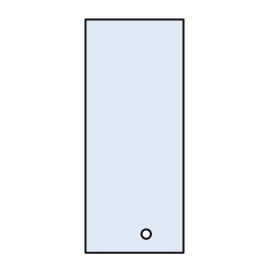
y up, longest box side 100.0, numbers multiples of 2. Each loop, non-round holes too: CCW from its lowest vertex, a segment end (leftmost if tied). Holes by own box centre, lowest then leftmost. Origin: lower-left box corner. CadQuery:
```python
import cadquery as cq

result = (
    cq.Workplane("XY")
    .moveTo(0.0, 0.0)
    .lineTo(42.0, 0.0)
    .lineTo(42.0, 100.0)
    .lineTo(0.0, 100.0)
    .close()
    .moveTo(26.0, 8.0)
    .circle(2.0)
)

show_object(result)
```